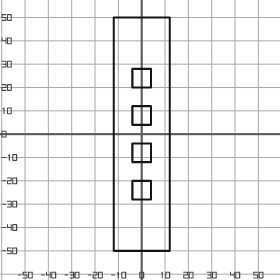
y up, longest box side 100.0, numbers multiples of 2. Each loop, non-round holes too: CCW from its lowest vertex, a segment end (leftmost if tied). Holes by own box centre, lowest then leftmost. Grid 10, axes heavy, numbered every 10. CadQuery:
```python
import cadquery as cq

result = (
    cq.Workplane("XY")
    .moveTo(-12.0, -50.0)
    .lineTo(12.0, -50.0)
    .lineTo(12.0, 50.0)
    .lineTo(-12.0, 50.0)
    .close()
    .moveTo(-4.0, -28.0)
    .lineTo(4.0, -28.0)
    .lineTo(4.0, -20.0)
    .lineTo(-4.0, -20.0)
    .close()
    .moveTo(-4.0, -12.0)
    .lineTo(4.0, -12.0)
    .lineTo(4.0, -4.0)
    .lineTo(-4.0, -4.0)
    .close()
    .moveTo(-4.0, 4.0)
    .lineTo(4.0, 4.0)
    .lineTo(4.0, 12.0)
    .lineTo(-4.0, 12.0)
    .close()
    .moveTo(-4.0, 20.0)
    .lineTo(4.0, 20.0)
    .lineTo(4.0, 28.0)
    .lineTo(-4.0, 28.0)
    .close()
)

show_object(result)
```